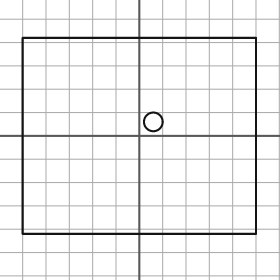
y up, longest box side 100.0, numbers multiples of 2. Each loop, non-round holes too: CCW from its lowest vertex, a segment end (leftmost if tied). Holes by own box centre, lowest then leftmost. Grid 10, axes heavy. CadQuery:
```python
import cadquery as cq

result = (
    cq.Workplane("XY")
    .moveTo(-50.0, -42.0)
    .lineTo(50.0, -42.0)
    .lineTo(50.0, 42.0)
    .lineTo(-50.0, 42.0)
    .close()
    .moveTo(6.0, 6.0)
    .circle(4.0)
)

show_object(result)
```